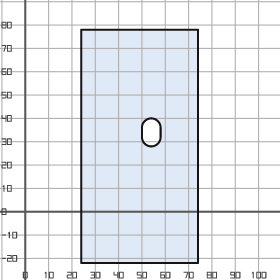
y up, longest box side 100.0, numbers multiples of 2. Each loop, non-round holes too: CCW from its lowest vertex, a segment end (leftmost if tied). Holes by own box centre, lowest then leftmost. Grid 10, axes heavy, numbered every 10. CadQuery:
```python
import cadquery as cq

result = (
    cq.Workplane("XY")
    .moveTo(24.0, -22.0)
    .lineTo(74.0, -22.0)
    .lineTo(74.0, 78.0)
    .lineTo(24.0, 78.0)
    .close()
    .moveTo(50.0, 32.0)
    .threePointArc((54.0, 28.0), (58.0, 32.0))
    .lineTo(58.0, 36.0)
    .threePointArc((54.0, 40.0), (50.0, 36.0))
    .close()
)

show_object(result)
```